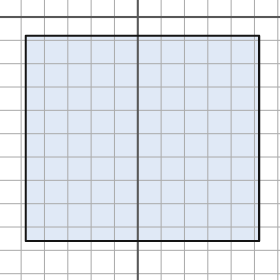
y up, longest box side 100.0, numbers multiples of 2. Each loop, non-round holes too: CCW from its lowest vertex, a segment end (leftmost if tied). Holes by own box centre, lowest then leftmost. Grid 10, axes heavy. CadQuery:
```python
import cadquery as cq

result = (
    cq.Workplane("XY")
    .moveTo(-48.0, -96.0)
    .lineTo(52.0, -96.0)
    .lineTo(52.0, -8.0)
    .lineTo(-48.0, -8.0)
    .close()
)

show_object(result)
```